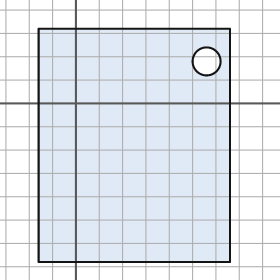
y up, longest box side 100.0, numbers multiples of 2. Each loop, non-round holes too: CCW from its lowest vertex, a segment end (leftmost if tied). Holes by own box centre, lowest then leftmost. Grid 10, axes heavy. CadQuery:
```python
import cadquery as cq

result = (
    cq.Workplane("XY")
    .moveTo(-16.0, -68.0)
    .lineTo(66.0, -68.0)
    .lineTo(66.0, 32.0)
    .lineTo(-16.0, 32.0)
    .close()
    .moveTo(56.0, 18.0)
    .circle(6.0)
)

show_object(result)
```